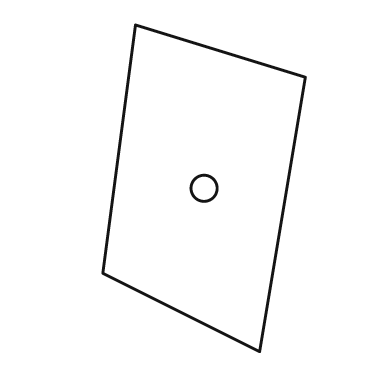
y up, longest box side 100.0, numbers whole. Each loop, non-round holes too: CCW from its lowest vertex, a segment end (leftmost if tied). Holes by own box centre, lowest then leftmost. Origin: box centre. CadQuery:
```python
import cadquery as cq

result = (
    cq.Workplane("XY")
    .moveTo(17.0, -50.0)
    .lineTo(31.0, 34.0)
    .lineTo(-21.0, 50.0)
    .lineTo(-31.0, -26.0)
    .close()
    .moveTo(0.0, 0.0)
    .circle(4.0)
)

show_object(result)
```